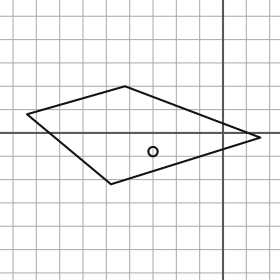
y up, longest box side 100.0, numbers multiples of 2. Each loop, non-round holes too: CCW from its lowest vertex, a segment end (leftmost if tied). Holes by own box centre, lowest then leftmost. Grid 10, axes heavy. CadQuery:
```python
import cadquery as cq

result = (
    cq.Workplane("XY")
    .moveTo(-48.0, -22.0)
    .lineTo(16.0, -2.0)
    .lineTo(-42.0, 20.0)
    .lineTo(-84.0, 8.0)
    .close()
    .moveTo(-30.0, -8.0)
    .circle(2.0)
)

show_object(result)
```